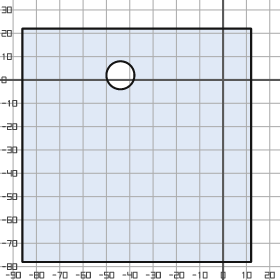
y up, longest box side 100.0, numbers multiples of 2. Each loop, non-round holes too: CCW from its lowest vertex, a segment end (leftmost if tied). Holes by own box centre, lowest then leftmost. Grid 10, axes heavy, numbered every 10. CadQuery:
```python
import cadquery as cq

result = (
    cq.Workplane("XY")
    .moveTo(-86.0, -78.0)
    .lineTo(12.0, -78.0)
    .lineTo(12.0, 22.0)
    .lineTo(-86.0, 22.0)
    .close()
    .moveTo(-44.0, 2.0)
    .circle(6.0)
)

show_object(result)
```